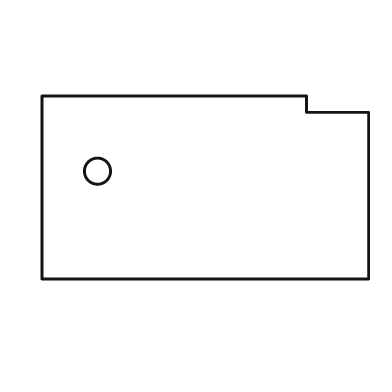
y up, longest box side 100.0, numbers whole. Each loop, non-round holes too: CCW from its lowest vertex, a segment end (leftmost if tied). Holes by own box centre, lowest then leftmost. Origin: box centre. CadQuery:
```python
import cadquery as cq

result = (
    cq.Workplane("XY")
    .moveTo(-50.0, -28.0)
    .lineTo(50.0, -28.0)
    .lineTo(50.0, 23.0)
    .lineTo(31.0, 23.0)
    .lineTo(31.0, 28.0)
    .lineTo(-50.0, 28.0)
    .close()
    .moveTo(-33.0, 5.0)
    .circle(4.0)
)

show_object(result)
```